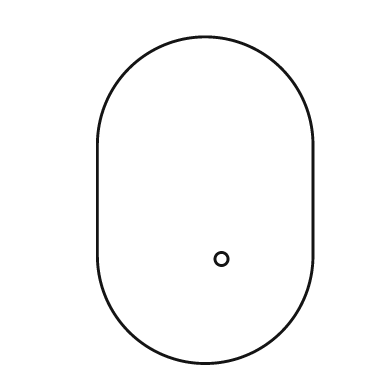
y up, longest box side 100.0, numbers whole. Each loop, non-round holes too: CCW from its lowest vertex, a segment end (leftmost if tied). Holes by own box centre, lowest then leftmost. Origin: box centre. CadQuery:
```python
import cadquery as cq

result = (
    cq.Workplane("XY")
    .moveTo(-33.0, -17.0)
    .threePointArc((0.0, -50.0), (33.0, -17.0))
    .lineTo(33.0, 17.0)
    .threePointArc((0.0, 50.0), (-33.0, 17.0))
    .close()
    .moveTo(5.0, -18.0)
    .circle(2.0)
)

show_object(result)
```